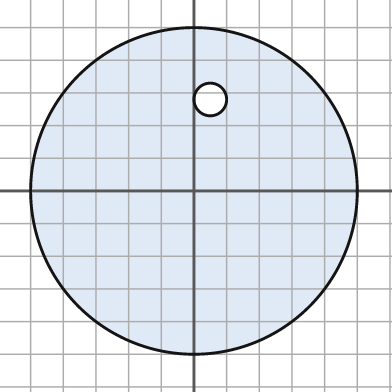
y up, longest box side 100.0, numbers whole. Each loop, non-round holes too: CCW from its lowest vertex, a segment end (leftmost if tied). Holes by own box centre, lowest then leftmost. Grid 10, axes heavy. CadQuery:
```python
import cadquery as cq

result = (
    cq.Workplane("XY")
    .moveTo(0.0, 0.0)
    .circle(50.0)
    .moveTo(5.0, 28.0)
    .circle(5.0)
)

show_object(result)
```